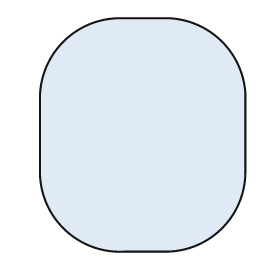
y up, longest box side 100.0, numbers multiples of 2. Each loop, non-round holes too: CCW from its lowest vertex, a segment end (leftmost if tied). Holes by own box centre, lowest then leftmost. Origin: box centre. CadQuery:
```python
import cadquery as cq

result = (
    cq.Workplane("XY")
    .moveTo(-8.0, -50.0)
    .lineTo(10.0, -50.0)
    .threePointArc((34.0, -40.0), (44.0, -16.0))
    .lineTo(44.0, 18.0)
    .threePointArc((34.0, 40.0), (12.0, 50.0))
    .lineTo(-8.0, 50.0)
    .threePointArc((-34.0, 40.0), (-44.0, 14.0))
    .lineTo(-44.0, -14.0)
    .threePointArc((-34.0, -40.0), (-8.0, -50.0))
    .close()
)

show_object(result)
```